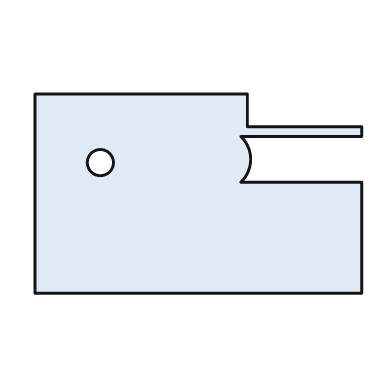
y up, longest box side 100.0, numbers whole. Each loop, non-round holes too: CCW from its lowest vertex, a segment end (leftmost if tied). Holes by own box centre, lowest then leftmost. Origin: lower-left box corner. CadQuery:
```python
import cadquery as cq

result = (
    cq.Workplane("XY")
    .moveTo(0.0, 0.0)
    .lineTo(100.0, 0.0)
    .lineTo(100.0, 34.0)
    .lineTo(63.0, 34.0)
    .threePointArc((66.0, 41.0), (63.0, 48.0))
    .lineTo(100.0, 48.0)
    .lineTo(100.0, 51.0)
    .lineTo(65.0, 51.0)
    .lineTo(65.0, 61.0)
    .lineTo(0.0, 61.0)
    .close()
    .moveTo(20.0, 40.0)
    .circle(4.0)
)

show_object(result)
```